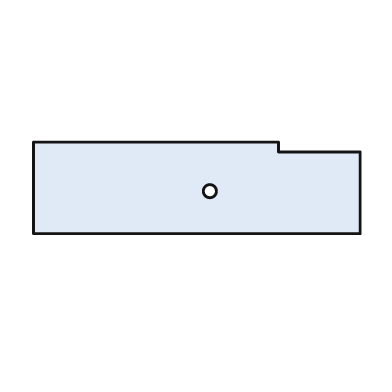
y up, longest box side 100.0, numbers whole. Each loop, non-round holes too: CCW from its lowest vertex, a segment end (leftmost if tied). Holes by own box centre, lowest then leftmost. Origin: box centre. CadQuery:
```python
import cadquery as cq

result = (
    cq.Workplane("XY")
    .moveTo(-50.0, -14.0)
    .lineTo(50.0, -14.0)
    .lineTo(50.0, 11.0)
    .lineTo(25.0, 11.0)
    .lineTo(25.0, 14.0)
    .lineTo(-50.0, 14.0)
    .close()
    .moveTo(4.0, -1.0)
    .circle(2.0)
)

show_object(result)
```